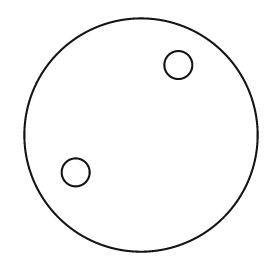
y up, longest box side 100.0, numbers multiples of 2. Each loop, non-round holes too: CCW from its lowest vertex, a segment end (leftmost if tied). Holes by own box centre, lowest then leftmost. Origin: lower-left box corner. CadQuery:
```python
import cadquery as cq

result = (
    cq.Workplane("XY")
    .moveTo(50.0, 50.0)
    .circle(50.0)
    .moveTo(22.0, 34.0)
    .circle(6.0)
    .moveTo(66.0, 80.0)
    .circle(6.0)
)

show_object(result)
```